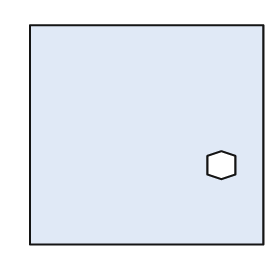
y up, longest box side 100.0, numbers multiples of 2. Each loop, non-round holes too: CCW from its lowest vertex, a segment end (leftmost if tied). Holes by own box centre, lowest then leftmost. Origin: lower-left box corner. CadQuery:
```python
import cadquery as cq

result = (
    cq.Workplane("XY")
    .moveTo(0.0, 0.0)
    .lineTo(100.0, 0.0)
    .lineTo(100.0, 94.0)
    .lineTo(0.0, 94.0)
    .close()
    .moveTo(82.0, 28.0)
    .lineTo(88.0, 30.0)
    .lineTo(88.0, 38.0)
    .lineTo(82.0, 40.0)
    .lineTo(76.0, 38.0)
    .lineTo(76.0, 30.0)
    .close()
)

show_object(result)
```